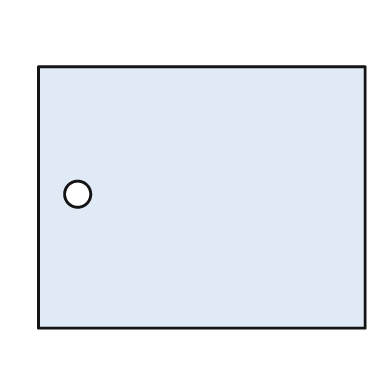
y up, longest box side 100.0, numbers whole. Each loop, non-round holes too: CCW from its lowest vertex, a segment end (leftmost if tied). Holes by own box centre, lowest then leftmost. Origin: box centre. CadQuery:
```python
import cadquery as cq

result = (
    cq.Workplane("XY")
    .moveTo(-50.0, -40.0)
    .lineTo(50.0, -40.0)
    .lineTo(50.0, 40.0)
    .lineTo(-50.0, 40.0)
    .close()
    .moveTo(-38.0, 1.0)
    .circle(4.0)
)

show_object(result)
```